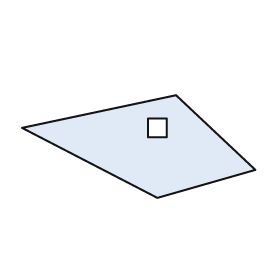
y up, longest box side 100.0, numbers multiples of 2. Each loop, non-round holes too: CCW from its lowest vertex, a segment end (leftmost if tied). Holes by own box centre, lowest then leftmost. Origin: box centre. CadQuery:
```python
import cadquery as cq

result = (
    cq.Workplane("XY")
    .moveTo(8.0, -22.0)
    .lineTo(50.0, -10.0)
    .lineTo(16.0, 22.0)
    .lineTo(-50.0, 8.0)
    .close()
    .moveTo(4.0, 4.0)
    .lineTo(12.0, 4.0)
    .lineTo(12.0, 12.0)
    .lineTo(4.0, 12.0)
    .close()
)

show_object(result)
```